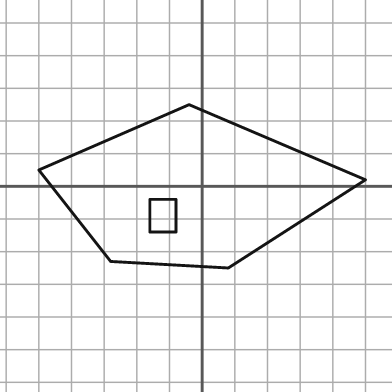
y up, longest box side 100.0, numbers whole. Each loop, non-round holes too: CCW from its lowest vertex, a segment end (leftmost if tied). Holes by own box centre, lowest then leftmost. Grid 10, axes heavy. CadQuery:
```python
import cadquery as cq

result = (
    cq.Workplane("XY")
    .moveTo(8.0, -25.0)
    .lineTo(50.0, 2.0)
    .lineTo(-4.0, 25.0)
    .lineTo(-50.0, 5.0)
    .lineTo(-28.0, -23.0)
    .close()
    .moveTo(-16.0, -14.0)
    .lineTo(-8.0, -14.0)
    .lineTo(-8.0, -4.0)
    .lineTo(-16.0, -4.0)
    .close()
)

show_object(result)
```